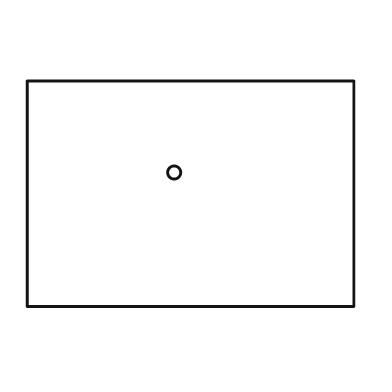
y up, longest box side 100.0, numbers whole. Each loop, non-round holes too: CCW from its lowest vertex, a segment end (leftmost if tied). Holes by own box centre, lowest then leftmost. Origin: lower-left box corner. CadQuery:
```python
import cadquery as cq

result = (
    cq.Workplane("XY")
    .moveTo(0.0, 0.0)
    .lineTo(100.0, 0.0)
    .lineTo(100.0, 69.0)
    .lineTo(0.0, 69.0)
    .close()
    .moveTo(45.0, 41.0)
    .circle(2.0)
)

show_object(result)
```